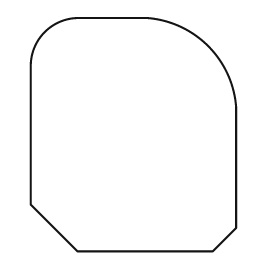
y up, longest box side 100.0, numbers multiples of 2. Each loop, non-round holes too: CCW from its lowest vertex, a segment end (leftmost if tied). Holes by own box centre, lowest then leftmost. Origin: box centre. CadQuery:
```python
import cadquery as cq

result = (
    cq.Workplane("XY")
    .moveTo(-24.0, -50.0)
    .lineTo(34.0, -50.0)
    .lineTo(44.0, -40.0)
    .lineTo(44.0, 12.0)
    .threePointArc((32.0, 38.0), (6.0, 50.0))
    .lineTo(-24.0, 50.0)
    .threePointArc((-38.0, 44.0), (-44.0, 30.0))
    .lineTo(-44.0, -30.0)
    .close()
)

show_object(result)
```